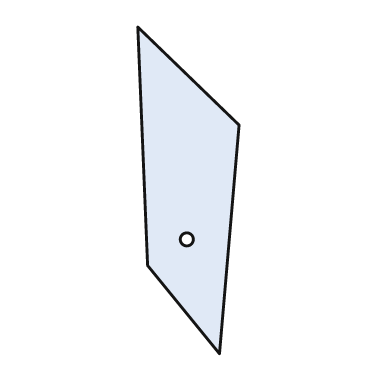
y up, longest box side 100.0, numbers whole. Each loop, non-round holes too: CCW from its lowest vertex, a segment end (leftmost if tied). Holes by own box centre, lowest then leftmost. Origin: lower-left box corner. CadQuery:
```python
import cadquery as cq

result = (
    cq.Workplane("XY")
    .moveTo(25.0, 0.0)
    .lineTo(31.0, 70.0)
    .lineTo(0.0, 100.0)
    .lineTo(3.0, 27.0)
    .close()
    .moveTo(15.0, 35.0)
    .circle(2.0)
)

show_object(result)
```